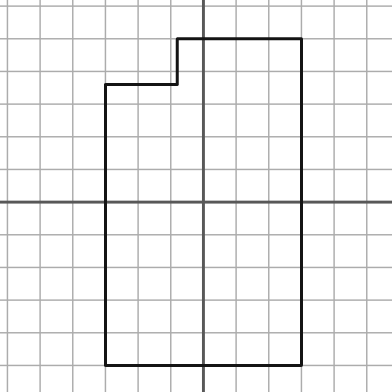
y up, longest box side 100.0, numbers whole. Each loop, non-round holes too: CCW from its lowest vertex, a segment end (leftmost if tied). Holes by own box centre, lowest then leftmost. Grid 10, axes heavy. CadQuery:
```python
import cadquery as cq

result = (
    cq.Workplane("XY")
    .moveTo(-30.0, -50.0)
    .lineTo(30.0, -50.0)
    .lineTo(30.0, 50.0)
    .lineTo(-8.0, 50.0)
    .lineTo(-8.0, 36.0)
    .lineTo(-30.0, 36.0)
    .close()
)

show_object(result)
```